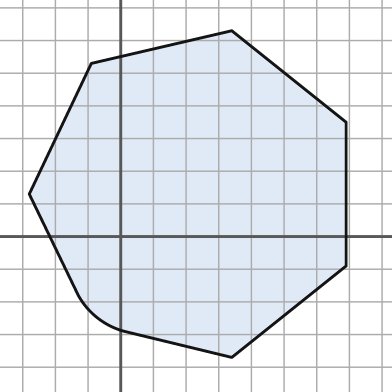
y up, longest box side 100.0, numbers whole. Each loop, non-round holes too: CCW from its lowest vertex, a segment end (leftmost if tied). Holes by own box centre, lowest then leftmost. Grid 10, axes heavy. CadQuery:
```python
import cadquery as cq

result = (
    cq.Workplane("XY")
    .moveTo(34.0, -37.0)
    .lineTo(69.0, -9.0)
    .lineTo(69.0, 35.0)
    .lineTo(34.0, 63.0)
    .lineTo(-9.0, 53.0)
    .lineTo(-28.0, 13.0)
    .lineTo(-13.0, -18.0)
    .threePointArc((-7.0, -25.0), (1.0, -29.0))
    .close()
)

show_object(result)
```